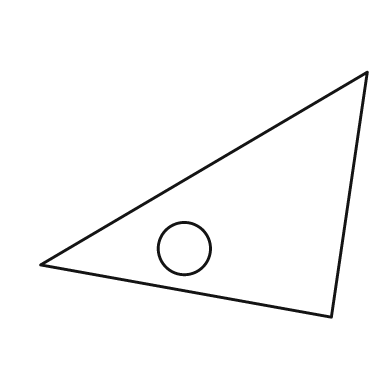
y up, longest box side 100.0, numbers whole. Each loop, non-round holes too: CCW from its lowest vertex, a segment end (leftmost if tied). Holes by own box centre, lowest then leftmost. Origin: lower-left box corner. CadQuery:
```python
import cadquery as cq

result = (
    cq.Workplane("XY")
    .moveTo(89.0, 0.0)
    .lineTo(100.0, 75.0)
    .lineTo(0.0, 16.0)
    .close()
    .moveTo(44.0, 21.0)
    .circle(8.0)
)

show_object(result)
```